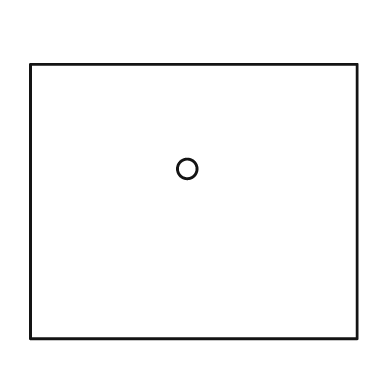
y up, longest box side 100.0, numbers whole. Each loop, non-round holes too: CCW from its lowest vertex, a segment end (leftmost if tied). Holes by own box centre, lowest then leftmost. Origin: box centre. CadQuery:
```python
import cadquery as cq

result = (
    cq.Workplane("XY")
    .moveTo(-50.0, -42.0)
    .lineTo(50.0, -42.0)
    .lineTo(50.0, 42.0)
    .lineTo(-50.0, 42.0)
    .close()
    .moveTo(-2.0, 10.0)
    .circle(3.0)
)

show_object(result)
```